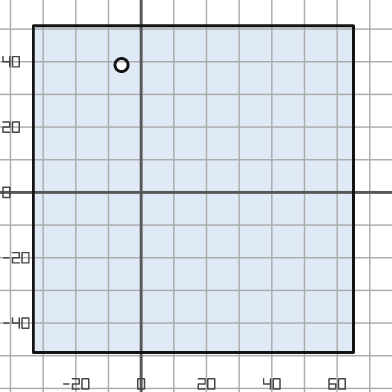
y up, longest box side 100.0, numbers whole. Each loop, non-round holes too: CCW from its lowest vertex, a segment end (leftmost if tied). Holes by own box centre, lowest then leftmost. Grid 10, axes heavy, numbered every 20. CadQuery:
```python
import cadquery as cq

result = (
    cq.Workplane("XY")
    .moveTo(-33.0, -49.0)
    .lineTo(65.0, -49.0)
    .lineTo(65.0, 51.0)
    .lineTo(-33.0, 51.0)
    .close()
    .moveTo(-6.0, 39.0)
    .circle(2.0)
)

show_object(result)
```